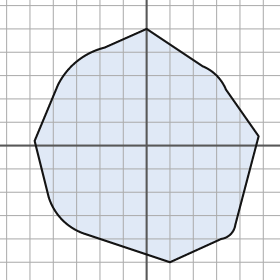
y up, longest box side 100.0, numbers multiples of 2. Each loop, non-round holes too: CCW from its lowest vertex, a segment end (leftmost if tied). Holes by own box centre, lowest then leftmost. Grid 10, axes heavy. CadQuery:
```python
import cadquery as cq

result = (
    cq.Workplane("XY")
    .moveTo(10.0, -50.0)
    .lineTo(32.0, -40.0)
    .threePointArc((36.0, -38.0), (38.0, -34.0))
    .lineTo(48.0, 4.0)
    .lineTo(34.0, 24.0)
    .threePointArc((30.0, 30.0), (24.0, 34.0))
    .lineTo(0.0, 50.0)
    .lineTo(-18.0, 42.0)
    .threePointArc((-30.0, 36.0), (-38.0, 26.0))
    .lineTo(-48.0, 2.0)
    .lineTo(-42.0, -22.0)
    .threePointArc((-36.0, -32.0), (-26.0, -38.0))
    .close()
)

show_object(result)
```